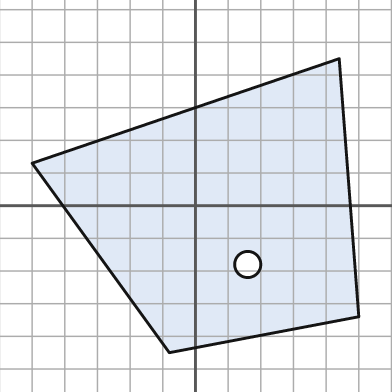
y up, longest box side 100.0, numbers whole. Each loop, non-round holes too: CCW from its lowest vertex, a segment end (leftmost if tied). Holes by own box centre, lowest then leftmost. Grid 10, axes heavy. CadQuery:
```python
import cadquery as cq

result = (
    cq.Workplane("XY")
    .moveTo(-8.0, -45.0)
    .lineTo(50.0, -34.0)
    .lineTo(44.0, 45.0)
    .lineTo(-50.0, 13.0)
    .close()
    .moveTo(16.0, -18.0)
    .circle(4.0)
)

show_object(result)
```